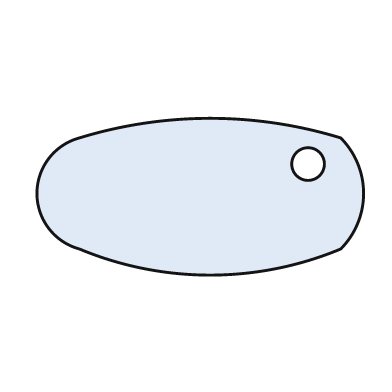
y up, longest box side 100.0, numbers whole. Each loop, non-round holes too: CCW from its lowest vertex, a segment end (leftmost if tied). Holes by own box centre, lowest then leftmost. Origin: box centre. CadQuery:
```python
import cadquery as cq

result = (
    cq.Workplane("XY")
    .moveTo(-37.0, -16.0)
    .threePointArc((3.0, -24.0), (43.0, -16.0))
    .threePointArc((50.0, 1.0), (43.0, 18.0))
    .threePointArc((3.0, 24.0), (-37.0, 18.0))
    .threePointArc((-50.0, 1.0), (-37.0, -16.0))
    .close()
    .moveTo(33.0, 10.0)
    .circle(5.0)
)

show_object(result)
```